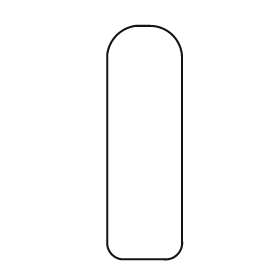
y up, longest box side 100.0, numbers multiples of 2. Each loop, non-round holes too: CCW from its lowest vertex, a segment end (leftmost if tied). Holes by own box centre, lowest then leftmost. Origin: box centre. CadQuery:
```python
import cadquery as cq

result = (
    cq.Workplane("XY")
    .moveTo(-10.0, -50.0)
    .lineTo(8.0, -50.0)
    .threePointArc((14.0, -48.0), (16.0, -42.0))
    .lineTo(16.0, 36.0)
    .threePointArc((12.0, 46.0), (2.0, 50.0))
    .lineTo(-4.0, 50.0)
    .threePointArc((-12.0, 46.0), (-16.0, 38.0))
    .lineTo(-16.0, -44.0)
    .threePointArc((-14.0, -48.0), (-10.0, -50.0))
    .close()
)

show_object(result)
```